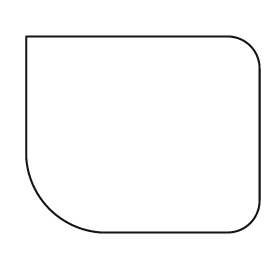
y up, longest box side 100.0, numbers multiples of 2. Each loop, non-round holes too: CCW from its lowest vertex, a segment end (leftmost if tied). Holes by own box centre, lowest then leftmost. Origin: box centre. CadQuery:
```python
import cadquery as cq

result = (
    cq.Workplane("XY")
    .moveTo(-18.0, -42.0)
    .lineTo(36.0, -42.0)
    .threePointArc((46.0, -38.0), (50.0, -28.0))
    .lineTo(50.0, 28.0)
    .threePointArc((46.0, 38.0), (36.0, 42.0))
    .lineTo(-50.0, 42.0)
    .lineTo(-50.0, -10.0)
    .threePointArc((-40.0, -32.0), (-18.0, -42.0))
    .close()
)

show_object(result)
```